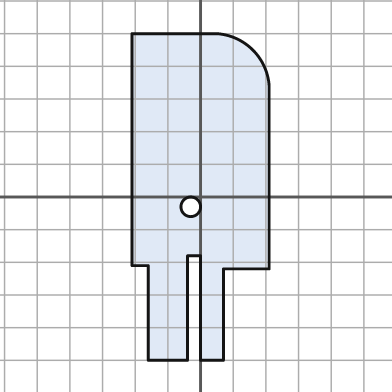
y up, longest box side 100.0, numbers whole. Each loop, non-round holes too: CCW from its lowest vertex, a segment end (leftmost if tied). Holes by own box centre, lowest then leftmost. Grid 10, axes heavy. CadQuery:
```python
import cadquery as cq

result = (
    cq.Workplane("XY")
    .moveTo(-16.0, -50.0)
    .lineTo(-4.0, -50.0)
    .lineTo(-4.0, -18.0)
    .lineTo(0.0, -18.0)
    .lineTo(0.0, -50.0)
    .lineTo(7.0, -50.0)
    .lineTo(7.0, -22.0)
    .lineTo(21.0, -22.0)
    .lineTo(21.0, 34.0)
    .threePointArc((16.0, 45.0), (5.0, 50.0))
    .lineTo(-21.0, 50.0)
    .lineTo(-21.0, -21.0)
    .lineTo(-16.0, -21.0)
    .close()
    .moveTo(-3.0, -3.0)
    .circle(3.0)
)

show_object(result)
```